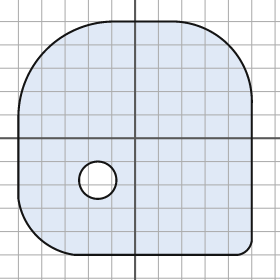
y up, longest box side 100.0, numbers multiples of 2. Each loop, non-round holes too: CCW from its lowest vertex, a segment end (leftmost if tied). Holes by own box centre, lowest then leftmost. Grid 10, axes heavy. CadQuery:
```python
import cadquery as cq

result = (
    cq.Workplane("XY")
    .moveTo(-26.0, -50.0)
    .lineTo(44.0, -50.0)
    .threePointArc((48.0, -48.0), (50.0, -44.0))
    .lineTo(50.0, 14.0)
    .threePointArc((40.0, 40.0), (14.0, 50.0))
    .lineTo(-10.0, 50.0)
    .threePointArc((-38.0, 38.0), (-50.0, 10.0))
    .lineTo(-50.0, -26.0)
    .threePointArc((-42.0, -42.0), (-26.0, -50.0))
    .close()
    .moveTo(-16.0, -18.0)
    .circle(8.0)
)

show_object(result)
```